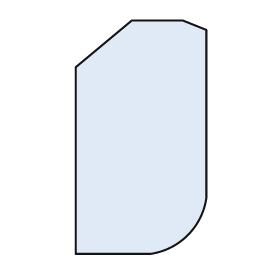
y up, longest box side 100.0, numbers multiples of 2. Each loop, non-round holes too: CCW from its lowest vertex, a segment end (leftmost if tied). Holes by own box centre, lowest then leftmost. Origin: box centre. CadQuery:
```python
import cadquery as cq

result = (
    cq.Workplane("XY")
    .moveTo(-28.0, -50.0)
    .lineTo(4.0, -50.0)
    .threePointArc((20.0, -42.0), (28.0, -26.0))
    .lineTo(28.0, 46.0)
    .lineTo(18.0, 50.0)
    .lineTo(-4.0, 50.0)
    .lineTo(-28.0, 30.0)
    .close()
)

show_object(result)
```